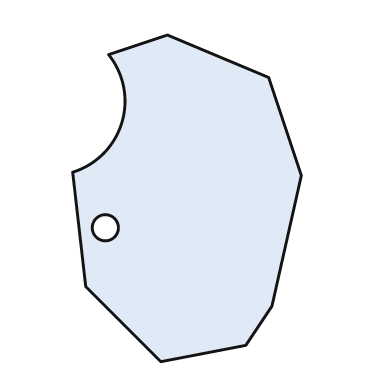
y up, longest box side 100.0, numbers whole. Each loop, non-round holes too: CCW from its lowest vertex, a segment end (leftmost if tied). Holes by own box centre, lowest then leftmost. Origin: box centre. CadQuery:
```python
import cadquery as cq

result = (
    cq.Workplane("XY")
    .moveTo(-8.0, -50.0)
    .lineTo(18.0, -45.0)
    .lineTo(26.0, -33.0)
    .lineTo(35.0, 7.0)
    .lineTo(25.0, 37.0)
    .lineTo(-6.0, 50.0)
    .lineTo(-24.0, 44.0)
    .threePointArc((-20.0, 23.0), (-35.0, 8.0))
    .lineTo(-31.0, -27.0)
    .close()
    .moveTo(-25.0, -9.0)
    .circle(4.0)
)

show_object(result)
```